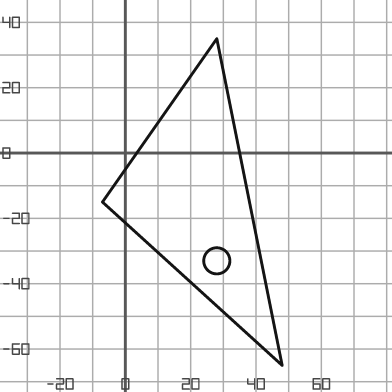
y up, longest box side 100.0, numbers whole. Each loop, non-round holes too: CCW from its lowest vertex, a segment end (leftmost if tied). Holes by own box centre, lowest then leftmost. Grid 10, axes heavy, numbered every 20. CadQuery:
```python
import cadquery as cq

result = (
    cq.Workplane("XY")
    .moveTo(48.0, -65.0)
    .lineTo(28.0, 35.0)
    .lineTo(-7.0, -15.0)
    .close()
    .moveTo(28.0, -33.0)
    .circle(4.0)
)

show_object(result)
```